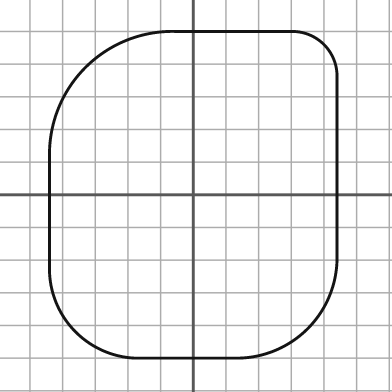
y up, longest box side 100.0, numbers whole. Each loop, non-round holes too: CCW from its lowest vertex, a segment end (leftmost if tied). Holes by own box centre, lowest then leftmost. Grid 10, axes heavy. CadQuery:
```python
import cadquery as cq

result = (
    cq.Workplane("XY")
    .moveTo(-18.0, -50.0)
    .lineTo(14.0, -50.0)
    .threePointArc((35.0, -41.0), (44.0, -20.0))
    .lineTo(44.0, 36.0)
    .threePointArc((40.0, 46.0), (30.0, 50.0))
    .lineTo(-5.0, 50.0)
    .threePointArc((-33.0, 39.0), (-44.0, 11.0))
    .lineTo(-44.0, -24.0)
    .threePointArc((-36.0, -42.0), (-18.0, -50.0))
    .close()
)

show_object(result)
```